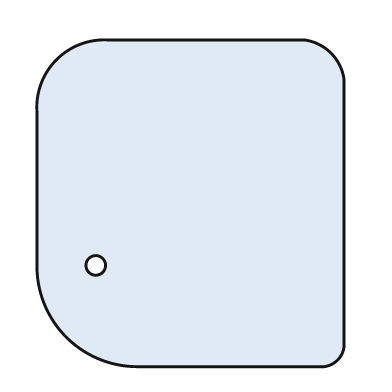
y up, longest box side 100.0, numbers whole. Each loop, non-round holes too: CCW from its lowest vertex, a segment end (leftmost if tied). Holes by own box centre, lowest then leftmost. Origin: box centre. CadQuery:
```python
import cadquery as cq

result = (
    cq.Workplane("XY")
    .moveTo(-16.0, -50.0)
    .lineTo(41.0, -50.0)
    .threePointArc((45.0, -48.0), (47.0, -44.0))
    .lineTo(47.0, 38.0)
    .threePointArc((43.0, 46.0), (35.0, 50.0))
    .lineTo(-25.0, 50.0)
    .threePointArc((-41.0, 44.0), (-47.0, 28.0))
    .lineTo(-47.0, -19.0)
    .threePointArc((-38.0, -41.0), (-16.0, -50.0))
    .close()
    .moveTo(-29.0, -19.0)
    .circle(3.0)
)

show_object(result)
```